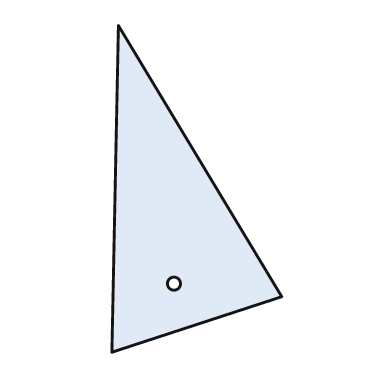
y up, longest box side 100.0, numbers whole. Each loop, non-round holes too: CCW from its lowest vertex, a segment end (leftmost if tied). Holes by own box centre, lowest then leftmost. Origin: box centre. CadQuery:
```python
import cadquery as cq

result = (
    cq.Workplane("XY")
    .moveTo(-26.0, -50.0)
    .lineTo(26.0, -33.0)
    .lineTo(-24.0, 50.0)
    .close()
    .moveTo(-7.0, -29.0)
    .circle(2.0)
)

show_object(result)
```